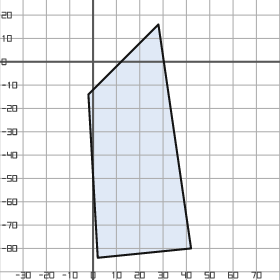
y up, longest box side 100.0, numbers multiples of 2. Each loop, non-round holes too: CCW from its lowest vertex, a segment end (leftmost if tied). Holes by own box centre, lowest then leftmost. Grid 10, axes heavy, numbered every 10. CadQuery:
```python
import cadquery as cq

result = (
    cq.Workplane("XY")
    .moveTo(2.0, -84.0)
    .lineTo(42.0, -80.0)
    .lineTo(28.0, 16.0)
    .lineTo(-2.0, -14.0)
    .close()
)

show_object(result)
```